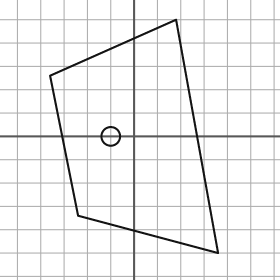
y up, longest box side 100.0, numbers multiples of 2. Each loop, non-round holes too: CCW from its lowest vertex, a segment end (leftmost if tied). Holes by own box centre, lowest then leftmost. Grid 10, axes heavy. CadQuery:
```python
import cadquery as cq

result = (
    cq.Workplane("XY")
    .moveTo(36.0, -50.0)
    .lineTo(18.0, 50.0)
    .lineTo(-36.0, 26.0)
    .lineTo(-24.0, -34.0)
    .close()
    .moveTo(-10.0, 0.0)
    .circle(4.0)
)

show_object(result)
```